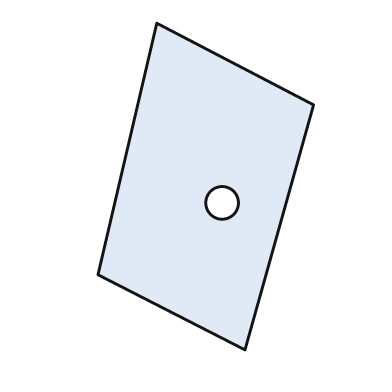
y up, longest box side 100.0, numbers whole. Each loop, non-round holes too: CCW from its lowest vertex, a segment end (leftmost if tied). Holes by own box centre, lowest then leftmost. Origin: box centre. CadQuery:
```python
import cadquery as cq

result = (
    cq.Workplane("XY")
    .moveTo(12.0, -50.0)
    .lineTo(33.0, 25.0)
    .lineTo(-15.0, 50.0)
    .lineTo(-33.0, -27.0)
    .close()
    .moveTo(5.0, -5.0)
    .circle(5.0)
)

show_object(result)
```